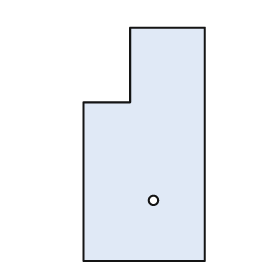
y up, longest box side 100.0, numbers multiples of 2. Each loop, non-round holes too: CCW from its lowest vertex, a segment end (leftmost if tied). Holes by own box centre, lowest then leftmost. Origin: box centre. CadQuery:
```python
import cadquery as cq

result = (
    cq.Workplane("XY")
    .moveTo(-26.0, -50.0)
    .lineTo(26.0, -50.0)
    .lineTo(26.0, 50.0)
    .lineTo(-6.0, 50.0)
    .lineTo(-6.0, 18.0)
    .lineTo(-26.0, 18.0)
    .close()
    .moveTo(4.0, -24.0)
    .circle(2.0)
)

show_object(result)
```